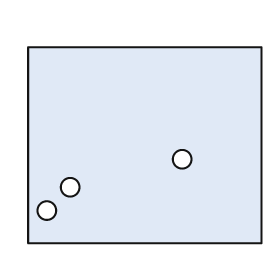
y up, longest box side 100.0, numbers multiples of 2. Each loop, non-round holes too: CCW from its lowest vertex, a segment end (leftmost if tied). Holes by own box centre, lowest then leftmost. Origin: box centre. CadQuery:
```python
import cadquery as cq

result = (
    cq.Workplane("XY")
    .moveTo(-50.0, -42.0)
    .lineTo(50.0, -42.0)
    .lineTo(50.0, 42.0)
    .lineTo(-50.0, 42.0)
    .close()
    .moveTo(-42.0, -28.0)
    .circle(4.0)
    .moveTo(-32.0, -18.0)
    .circle(4.0)
    .moveTo(16.0, -6.0)
    .circle(4.0)
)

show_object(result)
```